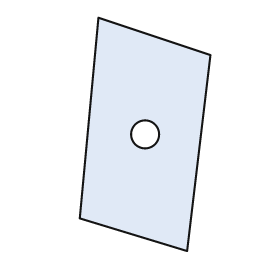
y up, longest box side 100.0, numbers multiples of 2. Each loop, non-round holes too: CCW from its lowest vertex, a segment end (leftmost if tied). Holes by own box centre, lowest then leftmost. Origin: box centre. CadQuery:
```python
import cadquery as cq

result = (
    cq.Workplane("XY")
    .moveTo(18.0, -50.0)
    .lineTo(28.0, 34.0)
    .lineTo(-20.0, 50.0)
    .lineTo(-28.0, -36.0)
    .close()
    .moveTo(0.0, 0.0)
    .circle(6.0)
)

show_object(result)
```